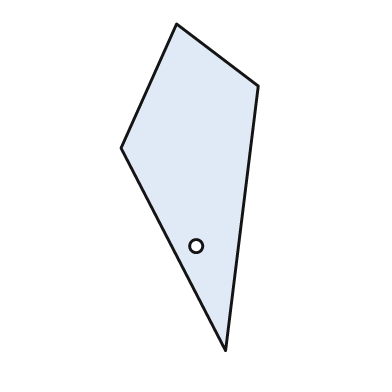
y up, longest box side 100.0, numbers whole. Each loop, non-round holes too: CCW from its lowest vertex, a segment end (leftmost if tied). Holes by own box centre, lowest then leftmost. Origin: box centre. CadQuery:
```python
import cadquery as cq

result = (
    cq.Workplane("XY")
    .moveTo(11.0, -50.0)
    .lineTo(21.0, 31.0)
    .lineTo(-4.0, 50.0)
    .lineTo(-21.0, 12.0)
    .close()
    .moveTo(2.0, -18.0)
    .circle(2.0)
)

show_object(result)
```